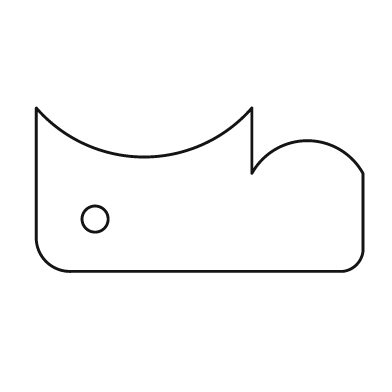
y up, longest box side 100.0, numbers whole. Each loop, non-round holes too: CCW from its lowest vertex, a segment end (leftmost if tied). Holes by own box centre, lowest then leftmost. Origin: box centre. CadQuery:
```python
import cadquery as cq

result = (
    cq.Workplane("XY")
    .moveTo(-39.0, -25.0)
    .lineTo(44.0, -25.0)
    .threePointArc((48.0, -23.0), (50.0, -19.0))
    .lineTo(50.0, 5.0)
    .threePointArc((33.0, 15.0), (16.0, 5.0))
    .lineTo(16.0, 25.0)
    .threePointArc((-17.0, 10.0), (-50.0, 25.0))
    .lineTo(-50.0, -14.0)
    .threePointArc((-47.0, -22.0), (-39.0, -25.0))
    .close()
    .moveTo(-32.0, -9.0)
    .circle(4.0)
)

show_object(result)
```